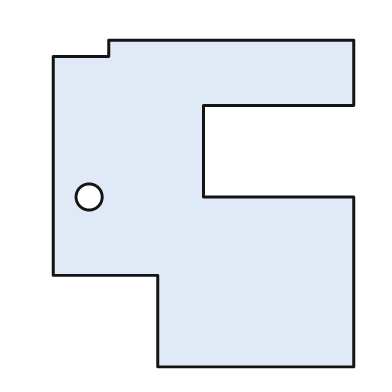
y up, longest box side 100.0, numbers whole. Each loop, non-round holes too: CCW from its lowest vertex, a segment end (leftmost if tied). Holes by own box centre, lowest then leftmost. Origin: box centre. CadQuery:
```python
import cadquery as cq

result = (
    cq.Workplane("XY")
    .moveTo(-14.0, -50.0)
    .lineTo(46.0, -50.0)
    .lineTo(46.0, 2.0)
    .lineTo(0.0, 2.0)
    .lineTo(0.0, 30.0)
    .lineTo(46.0, 30.0)
    .lineTo(46.0, 50.0)
    .lineTo(-29.0, 50.0)
    .lineTo(-29.0, 45.0)
    .lineTo(-46.0, 45.0)
    .lineTo(-46.0, -22.0)
    .lineTo(-14.0, -22.0)
    .close()
    .moveTo(-35.0, 2.0)
    .circle(4.0)
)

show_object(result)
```